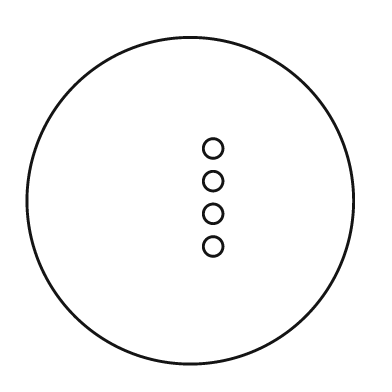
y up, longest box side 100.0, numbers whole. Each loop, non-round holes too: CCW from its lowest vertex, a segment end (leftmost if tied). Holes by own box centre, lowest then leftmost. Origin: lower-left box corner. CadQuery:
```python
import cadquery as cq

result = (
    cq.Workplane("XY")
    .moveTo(50.0, 50.0)
    .circle(50.0)
    .moveTo(57.0, 36.0)
    .circle(3.0)
    .moveTo(57.0, 46.0)
    .circle(3.0)
    .moveTo(57.0, 56.0)
    .circle(3.0)
    .moveTo(57.0, 66.0)
    .circle(3.0)
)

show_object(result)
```